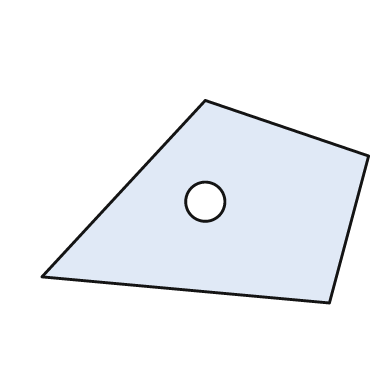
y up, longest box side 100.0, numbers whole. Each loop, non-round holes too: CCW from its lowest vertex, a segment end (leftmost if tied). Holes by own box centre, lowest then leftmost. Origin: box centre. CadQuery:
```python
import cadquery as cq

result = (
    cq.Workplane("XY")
    .moveTo(38.0, -31.0)
    .lineTo(50.0, 14.0)
    .lineTo(0.0, 31.0)
    .lineTo(-50.0, -23.0)
    .close()
    .moveTo(0.0, 0.0)
    .circle(6.0)
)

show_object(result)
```